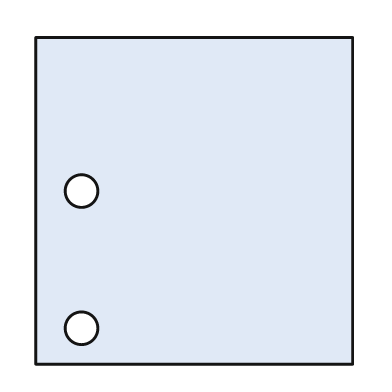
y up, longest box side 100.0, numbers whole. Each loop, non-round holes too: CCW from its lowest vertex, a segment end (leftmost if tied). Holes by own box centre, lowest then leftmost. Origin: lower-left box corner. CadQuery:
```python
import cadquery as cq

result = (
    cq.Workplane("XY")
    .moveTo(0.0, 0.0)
    .lineTo(97.0, 0.0)
    .lineTo(97.0, 100.0)
    .lineTo(0.0, 100.0)
    .close()
    .moveTo(14.0, 11.0)
    .circle(5.0)
    .moveTo(14.0, 53.0)
    .circle(5.0)
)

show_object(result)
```